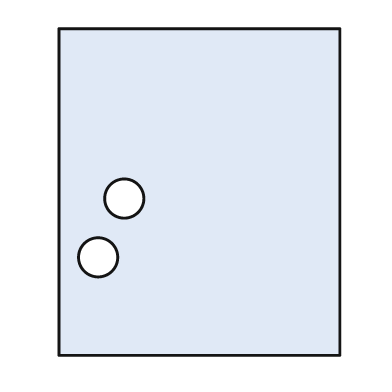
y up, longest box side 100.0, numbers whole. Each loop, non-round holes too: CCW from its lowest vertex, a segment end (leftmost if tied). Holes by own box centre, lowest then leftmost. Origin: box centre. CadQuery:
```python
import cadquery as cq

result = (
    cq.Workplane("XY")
    .moveTo(-43.0, -50.0)
    .lineTo(43.0, -50.0)
    .lineTo(43.0, 50.0)
    .lineTo(-43.0, 50.0)
    .close()
    .moveTo(-31.0, -20.0)
    .circle(6.0)
    .moveTo(-23.0, -2.0)
    .circle(6.0)
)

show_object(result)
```